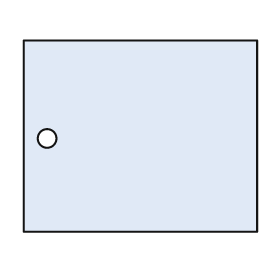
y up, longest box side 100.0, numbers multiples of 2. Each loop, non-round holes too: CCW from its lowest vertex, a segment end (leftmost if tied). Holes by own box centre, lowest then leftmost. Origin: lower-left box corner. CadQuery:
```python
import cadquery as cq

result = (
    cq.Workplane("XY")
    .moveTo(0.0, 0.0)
    .lineTo(100.0, 0.0)
    .lineTo(100.0, 82.0)
    .lineTo(0.0, 82.0)
    .close()
    .moveTo(10.0, 40.0)
    .circle(4.0)
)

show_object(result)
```